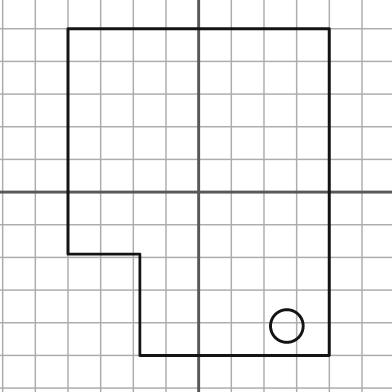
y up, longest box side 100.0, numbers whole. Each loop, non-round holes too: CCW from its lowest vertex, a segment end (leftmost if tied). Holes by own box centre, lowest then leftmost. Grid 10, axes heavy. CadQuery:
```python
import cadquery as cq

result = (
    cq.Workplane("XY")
    .moveTo(-18.0, -50.0)
    .lineTo(40.0, -50.0)
    .lineTo(40.0, 50.0)
    .lineTo(-40.0, 50.0)
    .lineTo(-40.0, -19.0)
    .lineTo(-18.0, -19.0)
    .close()
    .moveTo(27.0, -41.0)
    .circle(5.0)
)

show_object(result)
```